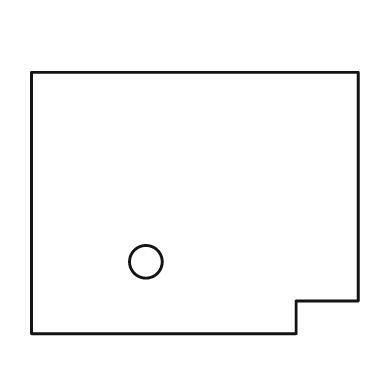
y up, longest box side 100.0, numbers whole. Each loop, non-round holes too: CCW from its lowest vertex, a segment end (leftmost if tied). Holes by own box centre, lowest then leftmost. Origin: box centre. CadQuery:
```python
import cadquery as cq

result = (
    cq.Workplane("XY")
    .moveTo(-50.0, -40.0)
    .lineTo(31.0, -40.0)
    .lineTo(31.0, -30.0)
    .lineTo(50.0, -30.0)
    .lineTo(50.0, 40.0)
    .lineTo(-50.0, 40.0)
    .close()
    .moveTo(-15.0, -18.0)
    .circle(5.0)
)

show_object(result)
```